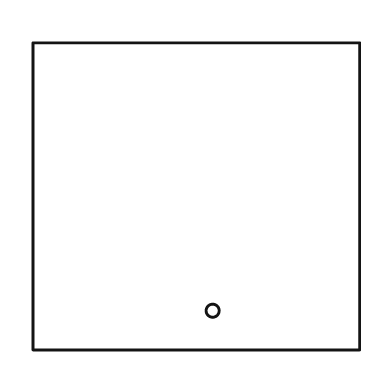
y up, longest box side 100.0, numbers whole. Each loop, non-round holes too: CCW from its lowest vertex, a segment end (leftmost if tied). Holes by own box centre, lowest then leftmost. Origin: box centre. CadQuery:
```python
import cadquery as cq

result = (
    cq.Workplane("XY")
    .moveTo(-50.0, -47.0)
    .lineTo(50.0, -47.0)
    .lineTo(50.0, 47.0)
    .lineTo(-50.0, 47.0)
    .close()
    .moveTo(5.0, -35.0)
    .circle(2.0)
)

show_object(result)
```